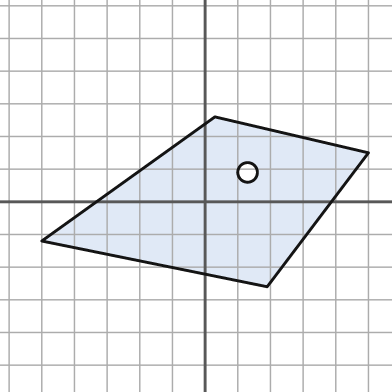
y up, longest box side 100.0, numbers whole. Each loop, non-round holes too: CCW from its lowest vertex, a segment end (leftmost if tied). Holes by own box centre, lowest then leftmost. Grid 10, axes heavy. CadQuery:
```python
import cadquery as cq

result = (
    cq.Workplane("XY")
    .moveTo(19.0, -26.0)
    .lineTo(50.0, 15.0)
    .lineTo(3.0, 26.0)
    .lineTo(-50.0, -12.0)
    .close()
    .moveTo(13.0, 9.0)
    .circle(3.0)
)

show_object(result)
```